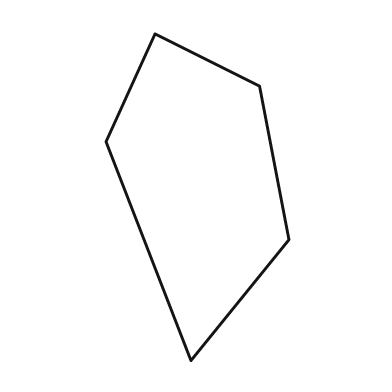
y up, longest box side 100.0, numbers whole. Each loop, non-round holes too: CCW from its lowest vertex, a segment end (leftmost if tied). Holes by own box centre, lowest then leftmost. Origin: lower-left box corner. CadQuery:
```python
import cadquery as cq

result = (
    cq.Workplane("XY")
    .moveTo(26.0, 0.0)
    .lineTo(56.0, 37.0)
    .lineTo(47.0, 84.0)
    .lineTo(15.0, 100.0)
    .lineTo(0.0, 67.0)
    .close()
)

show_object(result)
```